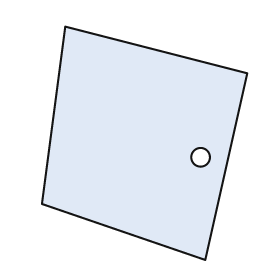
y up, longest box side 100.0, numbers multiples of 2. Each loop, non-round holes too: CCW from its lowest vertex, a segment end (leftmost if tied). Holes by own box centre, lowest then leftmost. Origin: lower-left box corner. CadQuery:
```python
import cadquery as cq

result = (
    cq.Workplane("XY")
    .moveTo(70.0, 0.0)
    .lineTo(88.0, 80.0)
    .lineTo(10.0, 100.0)
    .lineTo(0.0, 24.0)
    .close()
    .moveTo(68.0, 44.0)
    .circle(4.0)
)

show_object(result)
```